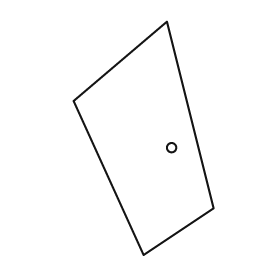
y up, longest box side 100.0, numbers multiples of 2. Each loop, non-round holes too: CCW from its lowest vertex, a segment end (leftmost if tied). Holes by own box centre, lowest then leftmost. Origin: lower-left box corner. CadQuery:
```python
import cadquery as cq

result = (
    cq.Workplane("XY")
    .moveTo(30.0, 0.0)
    .lineTo(60.0, 20.0)
    .lineTo(40.0, 100.0)
    .lineTo(0.0, 66.0)
    .close()
    .moveTo(42.0, 46.0)
    .circle(2.0)
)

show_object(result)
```